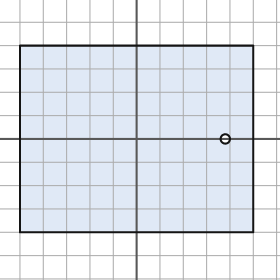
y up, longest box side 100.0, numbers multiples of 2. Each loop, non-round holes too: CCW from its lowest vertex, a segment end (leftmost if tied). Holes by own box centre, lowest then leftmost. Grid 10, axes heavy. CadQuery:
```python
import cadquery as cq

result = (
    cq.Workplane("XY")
    .moveTo(-50.0, -40.0)
    .lineTo(50.0, -40.0)
    .lineTo(50.0, 40.0)
    .lineTo(-50.0, 40.0)
    .close()
    .moveTo(38.0, 0.0)
    .circle(2.0)
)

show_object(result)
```